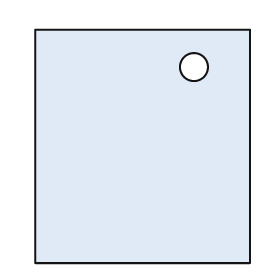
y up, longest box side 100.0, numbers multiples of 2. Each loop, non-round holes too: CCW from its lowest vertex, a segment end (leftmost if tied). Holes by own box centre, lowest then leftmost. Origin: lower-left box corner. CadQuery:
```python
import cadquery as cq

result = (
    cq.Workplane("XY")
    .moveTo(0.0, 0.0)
    .lineTo(92.0, 0.0)
    .lineTo(92.0, 100.0)
    .lineTo(0.0, 100.0)
    .close()
    .moveTo(68.0, 84.0)
    .circle(6.0)
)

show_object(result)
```